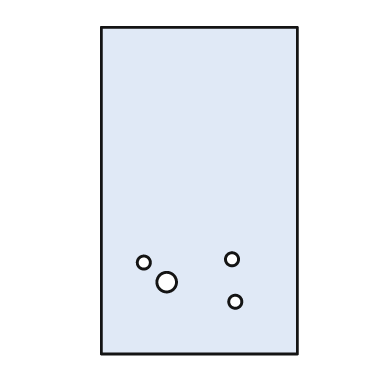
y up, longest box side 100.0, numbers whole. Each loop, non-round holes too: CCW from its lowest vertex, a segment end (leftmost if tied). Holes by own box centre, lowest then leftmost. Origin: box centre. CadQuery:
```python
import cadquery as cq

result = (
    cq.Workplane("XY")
    .moveTo(-30.0, -50.0)
    .lineTo(30.0, -50.0)
    .lineTo(30.0, 50.0)
    .lineTo(-30.0, 50.0)
    .close()
    .moveTo(11.0, -34.0)
    .circle(2.0)
    .moveTo(-10.0, -28.0)
    .circle(3.0)
    .moveTo(-17.0, -22.0)
    .circle(2.0)
    .moveTo(10.0, -21.0)
    .circle(2.0)
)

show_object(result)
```